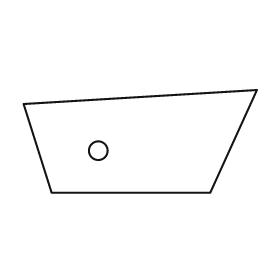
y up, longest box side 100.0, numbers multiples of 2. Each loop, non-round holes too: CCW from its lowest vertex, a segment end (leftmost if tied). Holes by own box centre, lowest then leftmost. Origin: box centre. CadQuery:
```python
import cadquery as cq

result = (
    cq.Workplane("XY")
    .moveTo(-38.0, -22.0)
    .lineTo(30.0, -22.0)
    .lineTo(50.0, 22.0)
    .lineTo(-50.0, 16.0)
    .close()
    .moveTo(-18.0, -4.0)
    .circle(4.0)
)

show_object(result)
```